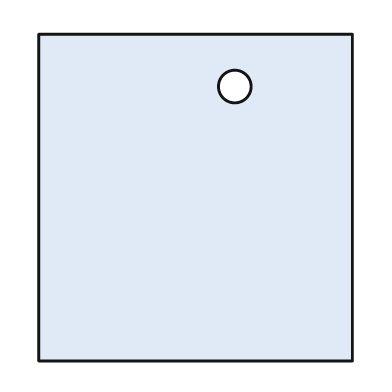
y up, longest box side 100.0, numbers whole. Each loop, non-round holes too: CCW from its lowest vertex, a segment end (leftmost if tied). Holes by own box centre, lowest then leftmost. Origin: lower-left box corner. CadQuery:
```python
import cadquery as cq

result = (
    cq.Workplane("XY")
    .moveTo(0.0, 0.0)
    .lineTo(96.0, 0.0)
    .lineTo(96.0, 100.0)
    .lineTo(0.0, 100.0)
    .close()
    .moveTo(60.0, 84.0)
    .circle(5.0)
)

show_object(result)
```